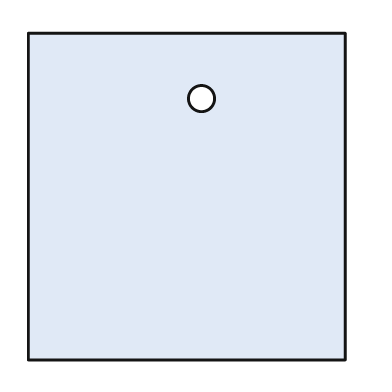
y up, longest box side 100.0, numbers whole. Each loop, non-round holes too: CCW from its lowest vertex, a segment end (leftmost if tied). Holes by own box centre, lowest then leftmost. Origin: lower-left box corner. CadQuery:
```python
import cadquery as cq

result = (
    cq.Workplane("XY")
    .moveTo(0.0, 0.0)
    .lineTo(97.0, 0.0)
    .lineTo(97.0, 100.0)
    .lineTo(0.0, 100.0)
    .close()
    .moveTo(53.0, 80.0)
    .circle(4.0)
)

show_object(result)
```